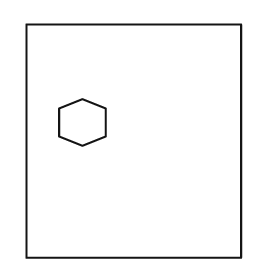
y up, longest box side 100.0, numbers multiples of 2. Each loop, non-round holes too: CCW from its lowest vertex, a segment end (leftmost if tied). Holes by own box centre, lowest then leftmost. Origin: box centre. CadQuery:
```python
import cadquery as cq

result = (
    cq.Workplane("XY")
    .moveTo(-46.0, -50.0)
    .lineTo(46.0, -50.0)
    .lineTo(46.0, 50.0)
    .lineTo(-46.0, 50.0)
    .close()
    .moveTo(-22.0, -2.0)
    .lineTo(-12.0, 2.0)
    .lineTo(-12.0, 14.0)
    .lineTo(-22.0, 18.0)
    .lineTo(-32.0, 14.0)
    .lineTo(-32.0, 2.0)
    .close()
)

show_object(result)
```